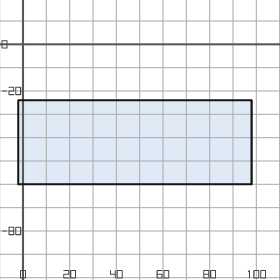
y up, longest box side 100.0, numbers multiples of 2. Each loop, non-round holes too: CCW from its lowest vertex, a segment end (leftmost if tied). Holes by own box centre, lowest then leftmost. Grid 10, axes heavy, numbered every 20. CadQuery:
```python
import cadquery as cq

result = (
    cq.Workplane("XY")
    .moveTo(-2.0, -60.0)
    .lineTo(98.0, -60.0)
    .lineTo(98.0, -24.0)
    .lineTo(-2.0, -24.0)
    .close()
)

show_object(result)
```